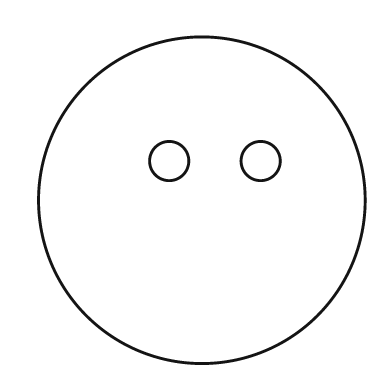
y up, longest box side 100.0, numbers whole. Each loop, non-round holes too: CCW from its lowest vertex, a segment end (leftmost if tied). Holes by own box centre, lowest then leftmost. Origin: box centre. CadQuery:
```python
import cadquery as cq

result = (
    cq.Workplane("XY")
    .moveTo(0.0, 0.0)
    .circle(50.0)
    .moveTo(-10.0, 12.0)
    .circle(6.0)
    .moveTo(18.0, 12.0)
    .circle(6.0)
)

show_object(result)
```